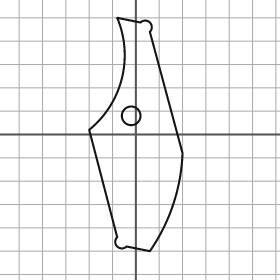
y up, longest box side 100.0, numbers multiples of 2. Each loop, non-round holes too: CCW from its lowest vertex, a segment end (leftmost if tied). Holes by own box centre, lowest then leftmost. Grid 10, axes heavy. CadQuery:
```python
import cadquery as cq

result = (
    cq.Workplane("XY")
    .moveTo(6.0, -50.0)
    .threePointArc((16.0, -30.0), (20.0, -8.0))
    .lineTo(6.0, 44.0)
    .threePointArc((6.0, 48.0), (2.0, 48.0))
    .lineTo(-8.0, 50.0)
    .threePointArc((-6.0, 24.0), (-20.0, 2.0))
    .lineTo(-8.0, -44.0)
    .threePointArc((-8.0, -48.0), (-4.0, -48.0))
    .close()
    .moveTo(-2.0, 8.0)
    .circle(4.0)
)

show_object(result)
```